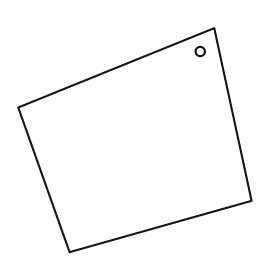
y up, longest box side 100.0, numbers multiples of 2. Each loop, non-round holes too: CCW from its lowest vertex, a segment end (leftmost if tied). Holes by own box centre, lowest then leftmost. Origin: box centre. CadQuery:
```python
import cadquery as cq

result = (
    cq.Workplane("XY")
    .moveTo(-28.0, -48.0)
    .lineTo(50.0, -26.0)
    .lineTo(34.0, 48.0)
    .lineTo(-50.0, 14.0)
    .close()
    .moveTo(28.0, 38.0)
    .circle(2.0)
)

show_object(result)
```